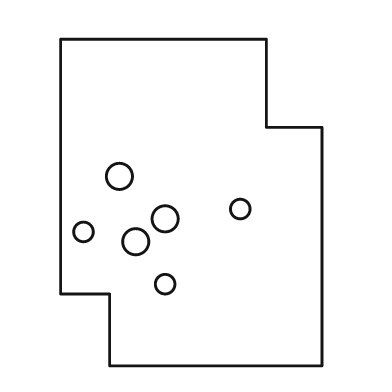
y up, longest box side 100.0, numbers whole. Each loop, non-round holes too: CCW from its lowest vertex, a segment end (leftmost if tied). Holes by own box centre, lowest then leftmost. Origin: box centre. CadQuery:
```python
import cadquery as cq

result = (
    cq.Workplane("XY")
    .moveTo(-25.0, -50.0)
    .lineTo(40.0, -50.0)
    .lineTo(40.0, 23.0)
    .lineTo(23.0, 23.0)
    .lineTo(23.0, 50.0)
    .lineTo(-40.0, 50.0)
    .lineTo(-40.0, -28.0)
    .lineTo(-25.0, -28.0)
    .close()
    .moveTo(-8.0, -25.0)
    .circle(3.0)
    .moveTo(-17.0, -12.0)
    .circle(4.0)
    .moveTo(-33.0, -9.0)
    .circle(3.0)
    .moveTo(-8.0, -5.0)
    .circle(4.0)
    .moveTo(15.0, -2.0)
    .circle(3.0)
    .moveTo(-22.0, 8.0)
    .circle(4.0)
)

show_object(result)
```